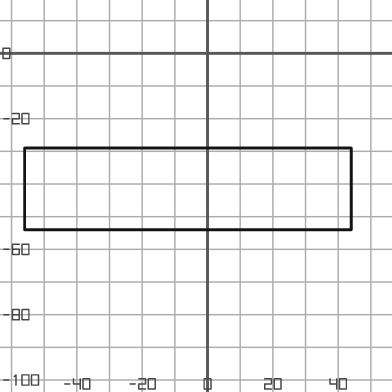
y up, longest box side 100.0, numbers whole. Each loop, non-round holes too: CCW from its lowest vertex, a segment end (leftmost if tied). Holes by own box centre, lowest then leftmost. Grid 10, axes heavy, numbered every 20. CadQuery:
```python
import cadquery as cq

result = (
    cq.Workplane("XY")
    .moveTo(-56.0, -54.0)
    .lineTo(44.0, -54.0)
    .lineTo(44.0, -29.0)
    .lineTo(-56.0, -29.0)
    .close()
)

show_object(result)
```